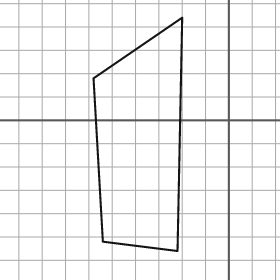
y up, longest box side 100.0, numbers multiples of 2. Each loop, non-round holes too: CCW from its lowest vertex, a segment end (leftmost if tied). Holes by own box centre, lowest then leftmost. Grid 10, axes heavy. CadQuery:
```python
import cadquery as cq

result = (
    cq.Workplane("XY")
    .moveTo(-22.0, -56.0)
    .lineTo(-20.0, 44.0)
    .lineTo(-58.0, 18.0)
    .lineTo(-54.0, -52.0)
    .close()
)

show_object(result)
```